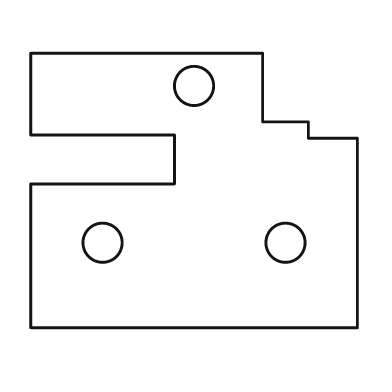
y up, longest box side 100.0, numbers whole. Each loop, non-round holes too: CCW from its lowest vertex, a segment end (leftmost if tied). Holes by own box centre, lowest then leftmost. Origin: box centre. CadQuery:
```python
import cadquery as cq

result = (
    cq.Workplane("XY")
    .moveTo(-50.0, -42.0)
    .lineTo(50.0, -42.0)
    .lineTo(50.0, 16.0)
    .lineTo(35.0, 16.0)
    .lineTo(35.0, 21.0)
    .lineTo(21.0, 21.0)
    .lineTo(21.0, 42.0)
    .lineTo(-50.0, 42.0)
    .lineTo(-50.0, 17.0)
    .lineTo(-6.0, 17.0)
    .lineTo(-6.0, 2.0)
    .lineTo(-50.0, 2.0)
    .close()
    .moveTo(-28.0, -16.0)
    .circle(6.0)
    .moveTo(28.0, -16.0)
    .circle(6.0)
    .moveTo(0.0, 32.0)
    .circle(6.0)
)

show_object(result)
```